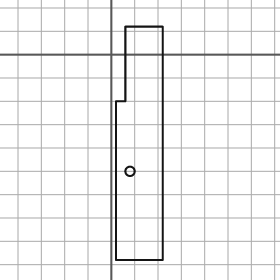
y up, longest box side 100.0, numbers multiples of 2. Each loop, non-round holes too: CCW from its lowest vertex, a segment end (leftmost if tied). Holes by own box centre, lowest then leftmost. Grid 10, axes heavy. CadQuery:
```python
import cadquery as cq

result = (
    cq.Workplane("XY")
    .moveTo(2.0, -88.0)
    .lineTo(22.0, -88.0)
    .lineTo(22.0, 12.0)
    .lineTo(6.0, 12.0)
    .lineTo(6.0, -20.0)
    .lineTo(2.0, -20.0)
    .close()
    .moveTo(8.0, -50.0)
    .circle(2.0)
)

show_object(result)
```